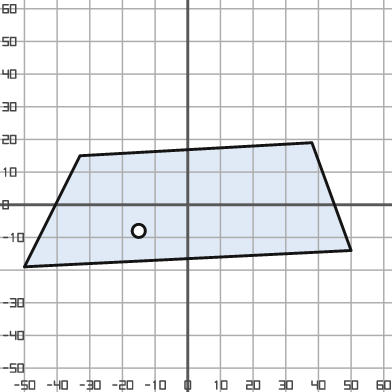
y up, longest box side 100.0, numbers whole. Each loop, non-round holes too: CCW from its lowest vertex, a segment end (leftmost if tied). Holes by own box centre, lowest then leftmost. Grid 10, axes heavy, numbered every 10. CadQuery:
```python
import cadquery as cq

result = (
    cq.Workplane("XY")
    .moveTo(-50.0, -19.0)
    .lineTo(50.0, -14.0)
    .lineTo(38.0, 19.0)
    .lineTo(-33.0, 15.0)
    .close()
    .moveTo(-15.0, -8.0)
    .circle(2.0)
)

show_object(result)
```